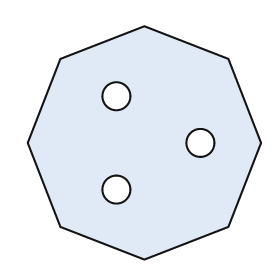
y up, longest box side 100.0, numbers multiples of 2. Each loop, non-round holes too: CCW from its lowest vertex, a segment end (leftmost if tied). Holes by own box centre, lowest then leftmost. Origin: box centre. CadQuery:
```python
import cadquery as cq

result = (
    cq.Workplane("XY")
    .moveTo(0.0, -50.0)
    .lineTo(36.0, -36.0)
    .lineTo(50.0, 0.0)
    .lineTo(36.0, 36.0)
    .lineTo(0.0, 50.0)
    .lineTo(-36.0, 36.0)
    .lineTo(-50.0, 0.0)
    .lineTo(-36.0, -36.0)
    .close()
    .moveTo(-12.0, -20.0)
    .circle(6.0)
    .moveTo(24.0, 0.0)
    .circle(6.0)
    .moveTo(-12.0, 20.0)
    .circle(6.0)
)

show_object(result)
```